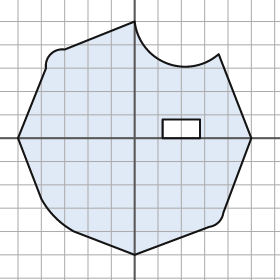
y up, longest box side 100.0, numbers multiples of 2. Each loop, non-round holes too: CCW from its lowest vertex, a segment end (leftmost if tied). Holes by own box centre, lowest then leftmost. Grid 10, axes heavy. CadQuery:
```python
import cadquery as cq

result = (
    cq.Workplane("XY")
    .moveTo(0.0, -50.0)
    .lineTo(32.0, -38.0)
    .threePointArc((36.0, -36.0), (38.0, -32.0))
    .lineTo(50.0, 0.0)
    .lineTo(36.0, 36.0)
    .threePointArc((14.0, 32.0), (0.0, 50.0))
    .lineTo(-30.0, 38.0)
    .threePointArc((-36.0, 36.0), (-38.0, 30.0))
    .lineTo(-50.0, 0.0)
    .lineTo(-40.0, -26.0)
    .threePointArc((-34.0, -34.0), (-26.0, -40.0))
    .close()
    .moveTo(12.0, 0.0)
    .lineTo(28.0, 0.0)
    .lineTo(28.0, 8.0)
    .lineTo(12.0, 8.0)
    .close()
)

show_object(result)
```